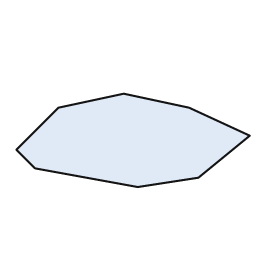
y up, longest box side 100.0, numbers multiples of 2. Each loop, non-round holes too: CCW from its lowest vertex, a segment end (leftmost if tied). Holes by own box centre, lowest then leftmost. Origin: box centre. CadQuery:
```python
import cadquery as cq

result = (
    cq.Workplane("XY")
    .moveTo(2.0, -20.0)
    .lineTo(28.0, -16.0)
    .lineTo(50.0, 2.0)
    .lineTo(24.0, 14.0)
    .lineTo(-4.0, 20.0)
    .lineTo(-32.0, 14.0)
    .lineTo(-50.0, -4.0)
    .lineTo(-42.0, -12.0)
    .close()
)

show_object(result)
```